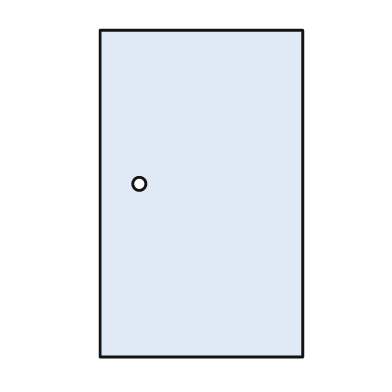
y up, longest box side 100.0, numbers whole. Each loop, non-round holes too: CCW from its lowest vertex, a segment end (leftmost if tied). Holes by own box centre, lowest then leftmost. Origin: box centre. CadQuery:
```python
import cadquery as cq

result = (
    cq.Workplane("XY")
    .moveTo(-31.0, -50.0)
    .lineTo(31.0, -50.0)
    .lineTo(31.0, 50.0)
    .lineTo(-31.0, 50.0)
    .close()
    .moveTo(-19.0, 3.0)
    .circle(2.0)
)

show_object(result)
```